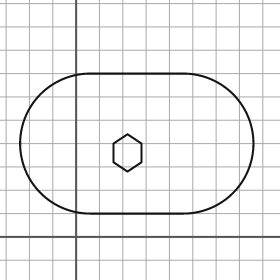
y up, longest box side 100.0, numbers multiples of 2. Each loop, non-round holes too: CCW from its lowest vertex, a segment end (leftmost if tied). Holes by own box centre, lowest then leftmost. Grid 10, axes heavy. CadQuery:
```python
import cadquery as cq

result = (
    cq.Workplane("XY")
    .moveTo(6.0, 10.0)
    .lineTo(46.0, 10.0)
    .threePointArc((76.0, 40.0), (46.0, 70.0))
    .lineTo(6.0, 70.0)
    .threePointArc((-24.0, 40.0), (6.0, 10.0))
    .close()
    .moveTo(22.0, 28.0)
    .lineTo(28.0, 32.0)
    .lineTo(28.0, 40.0)
    .lineTo(22.0, 44.0)
    .lineTo(16.0, 40.0)
    .lineTo(16.0, 32.0)
    .close()
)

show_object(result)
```